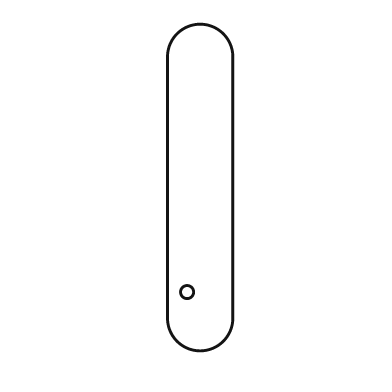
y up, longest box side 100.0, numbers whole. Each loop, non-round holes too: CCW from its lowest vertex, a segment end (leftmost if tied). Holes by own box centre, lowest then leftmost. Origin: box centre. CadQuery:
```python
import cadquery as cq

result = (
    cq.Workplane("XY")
    .moveTo(-10.0, -40.0)
    .threePointArc((0.0, -50.0), (10.0, -40.0))
    .lineTo(10.0, 40.0)
    .threePointArc((0.0, 50.0), (-10.0, 40.0))
    .close()
    .moveTo(-4.0, -32.0)
    .circle(2.0)
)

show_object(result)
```